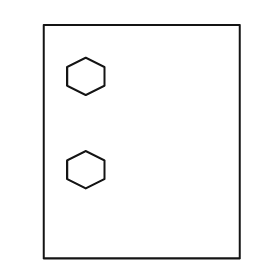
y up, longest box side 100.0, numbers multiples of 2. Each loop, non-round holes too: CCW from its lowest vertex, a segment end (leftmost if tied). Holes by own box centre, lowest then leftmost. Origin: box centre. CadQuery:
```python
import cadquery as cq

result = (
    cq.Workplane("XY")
    .moveTo(-42.0, -50.0)
    .lineTo(42.0, -50.0)
    .lineTo(42.0, 50.0)
    .lineTo(-42.0, 50.0)
    .close()
    .moveTo(-24.0, -20.0)
    .lineTo(-16.0, -16.0)
    .lineTo(-16.0, -8.0)
    .lineTo(-24.0, -4.0)
    .lineTo(-32.0, -8.0)
    .lineTo(-32.0, -16.0)
    .close()
    .moveTo(-24.0, 20.0)
    .lineTo(-16.0, 24.0)
    .lineTo(-16.0, 32.0)
    .lineTo(-24.0, 36.0)
    .lineTo(-32.0, 32.0)
    .lineTo(-32.0, 24.0)
    .close()
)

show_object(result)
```